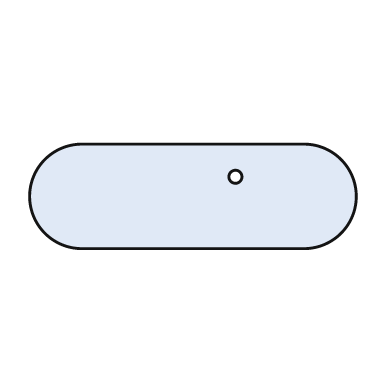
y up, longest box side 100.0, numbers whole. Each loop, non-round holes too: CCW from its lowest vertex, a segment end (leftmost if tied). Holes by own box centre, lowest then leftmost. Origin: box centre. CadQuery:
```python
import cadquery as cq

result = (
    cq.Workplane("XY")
    .moveTo(-34.0, -16.0)
    .lineTo(34.0, -16.0)
    .threePointArc((50.0, 0.0), (34.0, 16.0))
    .lineTo(-34.0, 16.0)
    .threePointArc((-50.0, 0.0), (-34.0, -16.0))
    .close()
    .moveTo(13.0, 6.0)
    .circle(2.0)
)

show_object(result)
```